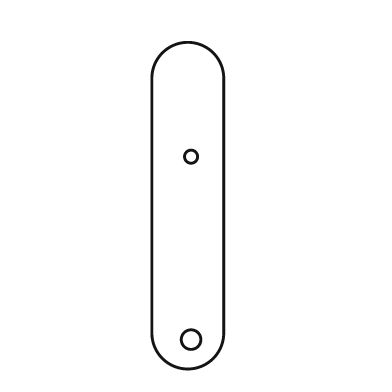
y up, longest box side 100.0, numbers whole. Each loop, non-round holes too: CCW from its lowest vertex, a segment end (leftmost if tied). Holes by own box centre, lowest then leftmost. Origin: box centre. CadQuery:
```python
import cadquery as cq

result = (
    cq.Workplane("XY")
    .moveTo(-11.0, -39.0)
    .threePointArc((0.0, -50.0), (11.0, -39.0))
    .lineTo(11.0, 39.0)
    .threePointArc((0.0, 50.0), (-11.0, 39.0))
    .close()
    .moveTo(1.0, -41.0)
    .circle(3.0)
    .moveTo(1.0, 15.0)
    .circle(2.0)
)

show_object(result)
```